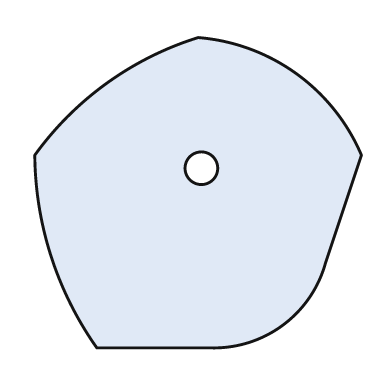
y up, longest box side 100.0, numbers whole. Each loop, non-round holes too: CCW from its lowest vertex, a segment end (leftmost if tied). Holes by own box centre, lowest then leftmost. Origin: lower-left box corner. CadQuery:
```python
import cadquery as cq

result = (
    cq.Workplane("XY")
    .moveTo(19.0, 0.0)
    .lineTo(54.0, 0.0)
    .threePointArc((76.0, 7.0), (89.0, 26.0))
    .lineTo(100.0, 59.0)
    .threePointArc((80.0, 84.0), (50.0, 95.0))
    .threePointArc((22.0, 81.0), (0.0, 59.0))
    .threePointArc((5.0, 28.0), (19.0, 0.0))
    .close()
    .moveTo(51.0, 55.0)
    .circle(5.0)
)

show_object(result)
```